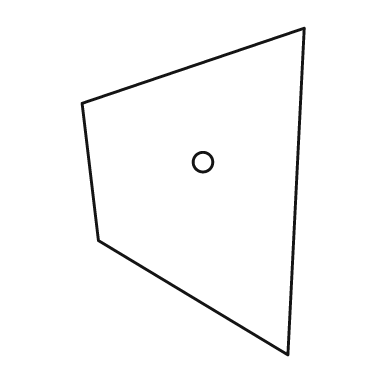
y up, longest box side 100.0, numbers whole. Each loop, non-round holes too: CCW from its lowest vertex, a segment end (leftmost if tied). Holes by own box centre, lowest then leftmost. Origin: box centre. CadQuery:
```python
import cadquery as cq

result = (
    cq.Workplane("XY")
    .moveTo(29.0, -50.0)
    .lineTo(34.0, 50.0)
    .lineTo(-34.0, 27.0)
    .lineTo(-29.0, -15.0)
    .close()
    .moveTo(3.0, 9.0)
    .circle(3.0)
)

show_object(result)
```